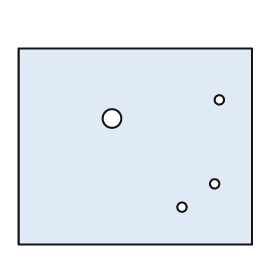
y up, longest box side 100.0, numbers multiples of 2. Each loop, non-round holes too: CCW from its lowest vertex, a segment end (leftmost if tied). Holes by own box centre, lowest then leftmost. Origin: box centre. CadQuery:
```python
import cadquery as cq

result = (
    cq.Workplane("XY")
    .moveTo(-50.0, -42.0)
    .lineTo(50.0, -42.0)
    .lineTo(50.0, 42.0)
    .lineTo(-50.0, 42.0)
    .close()
    .moveTo(20.0, -26.0)
    .circle(2.0)
    .moveTo(34.0, -16.0)
    .circle(2.0)
    .moveTo(-10.0, 12.0)
    .circle(4.0)
    .moveTo(36.0, 20.0)
    .circle(2.0)
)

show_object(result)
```